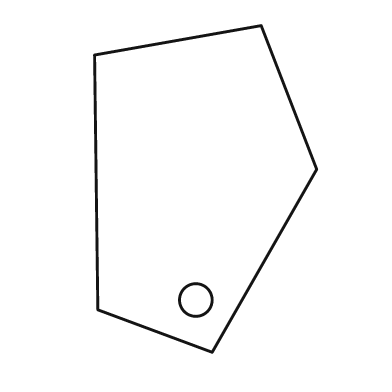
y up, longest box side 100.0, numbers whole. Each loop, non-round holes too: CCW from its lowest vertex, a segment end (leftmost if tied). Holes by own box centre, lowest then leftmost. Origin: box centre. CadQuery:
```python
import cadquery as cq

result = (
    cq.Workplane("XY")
    .moveTo(2.0, -50.0)
    .lineTo(34.0, 6.0)
    .lineTo(17.0, 50.0)
    .lineTo(-34.0, 41.0)
    .lineTo(-33.0, -37.0)
    .close()
    .moveTo(-3.0, -34.0)
    .circle(5.0)
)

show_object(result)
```